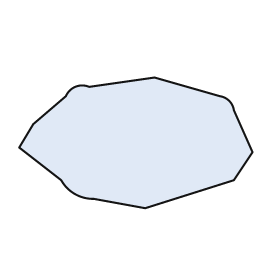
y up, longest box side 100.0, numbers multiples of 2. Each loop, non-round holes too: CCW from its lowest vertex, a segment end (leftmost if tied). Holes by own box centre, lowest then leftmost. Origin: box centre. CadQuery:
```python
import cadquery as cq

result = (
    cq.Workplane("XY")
    .moveTo(4.0, -28.0)
    .lineTo(42.0, -16.0)
    .lineTo(50.0, -4.0)
    .lineTo(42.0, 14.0)
    .threePointArc((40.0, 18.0), (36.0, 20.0))
    .lineTo(8.0, 28.0)
    .lineTo(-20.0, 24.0)
    .threePointArc((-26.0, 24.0), (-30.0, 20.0))
    .lineTo(-44.0, 8.0)
    .lineTo(-50.0, -2.0)
    .lineTo(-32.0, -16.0)
    .threePointArc((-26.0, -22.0), (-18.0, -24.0))
    .close()
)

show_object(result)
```